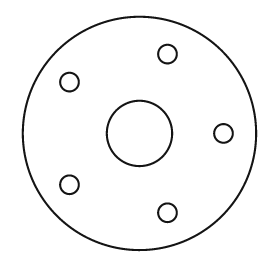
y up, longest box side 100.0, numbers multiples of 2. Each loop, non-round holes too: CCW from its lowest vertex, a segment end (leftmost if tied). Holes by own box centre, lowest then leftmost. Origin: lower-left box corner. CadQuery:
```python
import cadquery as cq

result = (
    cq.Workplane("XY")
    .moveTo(50.0, 50.0)
    .circle(50.0)
    .moveTo(62.0, 16.0)
    .circle(4.0)
    .moveTo(20.0, 28.0)
    .circle(4.0)
    .moveTo(50.0, 50.0)
    .circle(14.0)
    .moveTo(86.0, 50.0)
    .circle(4.0)
    .moveTo(20.0, 72.0)
    .circle(4.0)
    .moveTo(62.0, 84.0)
    .circle(4.0)
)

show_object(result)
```